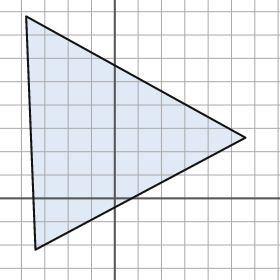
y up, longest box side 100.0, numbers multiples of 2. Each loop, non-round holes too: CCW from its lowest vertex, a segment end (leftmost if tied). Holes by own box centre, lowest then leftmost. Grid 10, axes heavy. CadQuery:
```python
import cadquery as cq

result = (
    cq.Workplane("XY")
    .moveTo(-34.0, -22.0)
    .lineTo(56.0, 26.0)
    .lineTo(-38.0, 78.0)
    .close()
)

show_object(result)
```